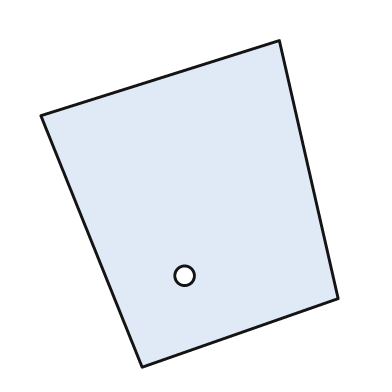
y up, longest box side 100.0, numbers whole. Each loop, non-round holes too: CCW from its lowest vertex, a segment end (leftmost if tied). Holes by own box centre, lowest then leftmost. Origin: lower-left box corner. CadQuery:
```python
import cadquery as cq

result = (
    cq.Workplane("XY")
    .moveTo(31.0, 0.0)
    .lineTo(91.0, 21.0)
    .lineTo(73.0, 100.0)
    .lineTo(0.0, 77.0)
    .close()
    .moveTo(44.0, 28.0)
    .circle(3.0)
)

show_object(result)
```